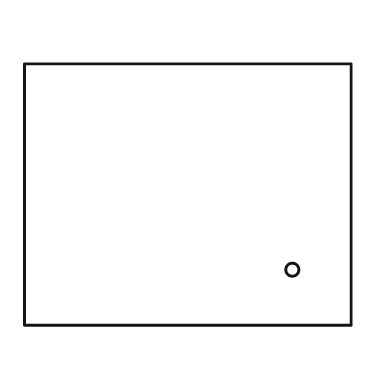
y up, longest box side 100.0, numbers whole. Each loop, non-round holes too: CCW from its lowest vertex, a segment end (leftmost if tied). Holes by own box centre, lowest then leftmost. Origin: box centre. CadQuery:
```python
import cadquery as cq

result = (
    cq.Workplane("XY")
    .moveTo(-50.0, -40.0)
    .lineTo(50.0, -40.0)
    .lineTo(50.0, 40.0)
    .lineTo(-50.0, 40.0)
    .close()
    .moveTo(32.0, -23.0)
    .circle(2.0)
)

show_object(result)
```